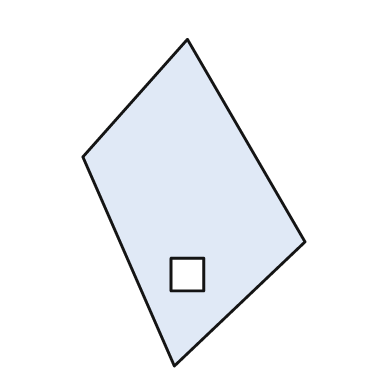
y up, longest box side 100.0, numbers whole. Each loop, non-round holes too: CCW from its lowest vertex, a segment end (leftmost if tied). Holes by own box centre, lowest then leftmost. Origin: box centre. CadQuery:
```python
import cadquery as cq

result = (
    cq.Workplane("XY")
    .moveTo(-6.0, -50.0)
    .lineTo(34.0, -12.0)
    .lineTo(-2.0, 50.0)
    .lineTo(-34.0, 14.0)
    .close()
    .moveTo(-7.0, -27.0)
    .lineTo(3.0, -27.0)
    .lineTo(3.0, -17.0)
    .lineTo(-7.0, -17.0)
    .close()
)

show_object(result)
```